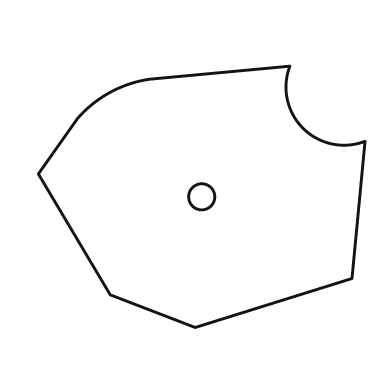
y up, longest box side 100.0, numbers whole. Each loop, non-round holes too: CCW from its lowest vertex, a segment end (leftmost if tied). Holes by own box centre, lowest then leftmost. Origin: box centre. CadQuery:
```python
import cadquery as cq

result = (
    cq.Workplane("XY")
    .moveTo(-2.0, -40.0)
    .lineTo(46.0, -25.0)
    .lineTo(50.0, 17.0)
    .threePointArc((31.0, 21.0), (27.0, 40.0))
    .lineTo(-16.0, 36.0)
    .threePointArc((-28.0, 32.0), (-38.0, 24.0))
    .lineTo(-50.0, 7.0)
    .lineTo(-28.0, -30.0)
    .close()
    .moveTo(0.0, 0.0)
    .circle(4.0)
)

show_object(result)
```